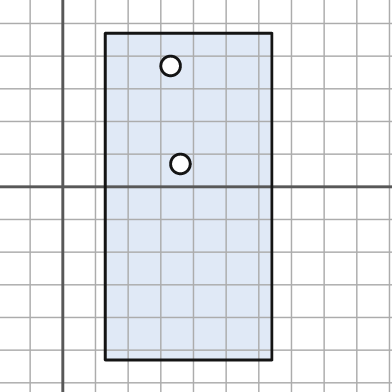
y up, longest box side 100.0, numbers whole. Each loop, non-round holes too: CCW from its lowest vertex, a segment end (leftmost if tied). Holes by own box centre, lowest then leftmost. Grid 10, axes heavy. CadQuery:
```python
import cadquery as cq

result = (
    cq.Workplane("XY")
    .moveTo(13.0, -53.0)
    .lineTo(64.0, -53.0)
    .lineTo(64.0, 47.0)
    .lineTo(13.0, 47.0)
    .close()
    .moveTo(36.0, 7.0)
    .circle(3.0)
    .moveTo(33.0, 37.0)
    .circle(3.0)
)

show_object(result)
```